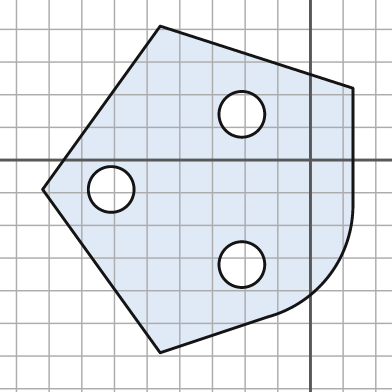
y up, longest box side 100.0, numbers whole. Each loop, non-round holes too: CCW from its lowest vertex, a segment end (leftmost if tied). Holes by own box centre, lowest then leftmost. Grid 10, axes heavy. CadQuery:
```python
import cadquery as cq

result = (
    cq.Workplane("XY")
    .moveTo(-46.0, -59.0)
    .lineTo(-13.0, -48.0)
    .threePointArc((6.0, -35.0), (13.0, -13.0))
    .lineTo(13.0, 22.0)
    .lineTo(-46.0, 41.0)
    .lineTo(-82.0, -9.0)
    .close()
    .moveTo(-21.0, -32.0)
    .circle(7.0)
    .moveTo(-61.0, -9.0)
    .circle(7.0)
    .moveTo(-21.0, 14.0)
    .circle(7.0)
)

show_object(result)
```